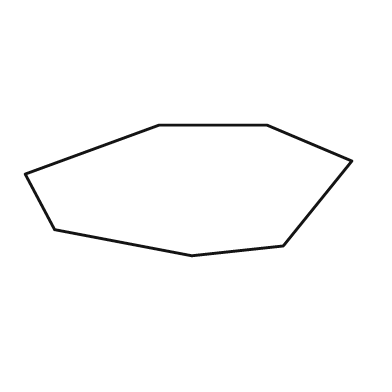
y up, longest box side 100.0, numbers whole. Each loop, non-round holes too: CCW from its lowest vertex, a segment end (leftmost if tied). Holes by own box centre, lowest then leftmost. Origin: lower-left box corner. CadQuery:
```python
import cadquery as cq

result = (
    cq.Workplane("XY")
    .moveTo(51.0, 0.0)
    .lineTo(79.0, 3.0)
    .lineTo(100.0, 29.0)
    .lineTo(74.0, 40.0)
    .lineTo(41.0, 40.0)
    .lineTo(0.0, 25.0)
    .lineTo(9.0, 8.0)
    .close()
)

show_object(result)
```